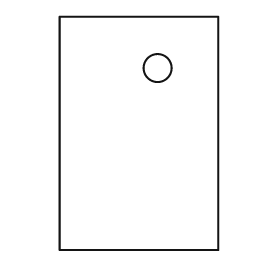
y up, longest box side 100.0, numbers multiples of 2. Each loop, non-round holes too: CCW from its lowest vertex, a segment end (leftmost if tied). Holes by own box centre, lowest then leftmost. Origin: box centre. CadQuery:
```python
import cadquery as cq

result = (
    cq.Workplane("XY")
    .moveTo(-34.0, -50.0)
    .lineTo(34.0, -50.0)
    .lineTo(34.0, 50.0)
    .lineTo(-34.0, 50.0)
    .close()
    .moveTo(8.0, 28.0)
    .circle(6.0)
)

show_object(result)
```